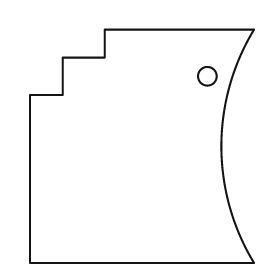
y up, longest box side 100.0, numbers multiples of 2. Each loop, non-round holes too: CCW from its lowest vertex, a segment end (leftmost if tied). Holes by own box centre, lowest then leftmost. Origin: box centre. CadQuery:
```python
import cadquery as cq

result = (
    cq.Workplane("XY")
    .moveTo(-48.0, -50.0)
    .lineTo(48.0, -50.0)
    .threePointArc((34.0, 0.0), (48.0, 50.0))
    .lineTo(-16.0, 50.0)
    .lineTo(-16.0, 38.0)
    .lineTo(-34.0, 38.0)
    .lineTo(-34.0, 22.0)
    .lineTo(-48.0, 22.0)
    .close()
    .moveTo(28.0, 30.0)
    .circle(4.0)
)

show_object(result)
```